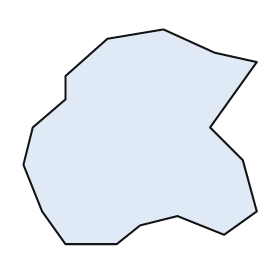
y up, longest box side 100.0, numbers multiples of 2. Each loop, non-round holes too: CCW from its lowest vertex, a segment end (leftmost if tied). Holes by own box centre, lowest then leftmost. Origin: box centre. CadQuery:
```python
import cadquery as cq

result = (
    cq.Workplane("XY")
    .moveTo(-32.0, -46.0)
    .lineTo(-10.0, -46.0)
    .lineTo(0.0, -38.0)
    .lineTo(16.0, -34.0)
    .lineTo(36.0, -42.0)
    .lineTo(50.0, -32.0)
    .lineTo(44.0, -10.0)
    .lineTo(30.0, 4.0)
    .lineTo(50.0, 32.0)
    .lineTo(32.0, 36.0)
    .lineTo(10.0, 46.0)
    .lineTo(-14.0, 42.0)
    .lineTo(-32.0, 26.0)
    .lineTo(-32.0, 16.0)
    .lineTo(-46.0, 4.0)
    .lineTo(-50.0, -12.0)
    .lineTo(-42.0, -32.0)
    .close()
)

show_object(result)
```